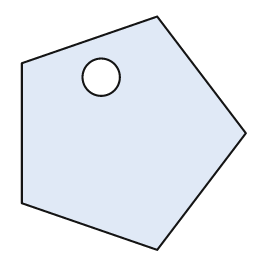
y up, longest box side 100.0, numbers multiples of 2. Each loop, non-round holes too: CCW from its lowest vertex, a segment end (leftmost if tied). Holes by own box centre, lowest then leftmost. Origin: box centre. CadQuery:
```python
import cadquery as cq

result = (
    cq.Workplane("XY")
    .moveTo(10.0, -50.0)
    .lineTo(48.0, 0.0)
    .lineTo(10.0, 50.0)
    .lineTo(-48.0, 30.0)
    .lineTo(-48.0, -30.0)
    .close()
    .moveTo(-14.0, 24.0)
    .circle(8.0)
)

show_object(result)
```